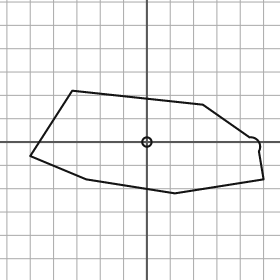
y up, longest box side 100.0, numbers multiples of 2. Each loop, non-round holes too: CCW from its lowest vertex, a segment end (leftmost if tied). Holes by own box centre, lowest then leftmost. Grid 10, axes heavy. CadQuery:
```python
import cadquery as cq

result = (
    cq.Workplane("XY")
    .moveTo(12.0, -22.0)
    .lineTo(50.0, -16.0)
    .lineTo(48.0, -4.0)
    .threePointArc((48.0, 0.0), (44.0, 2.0))
    .lineTo(24.0, 16.0)
    .lineTo(-32.0, 22.0)
    .lineTo(-50.0, -6.0)
    .lineTo(-26.0, -16.0)
    .close()
    .moveTo(0.0, 0.0)
    .circle(2.0)
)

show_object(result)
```